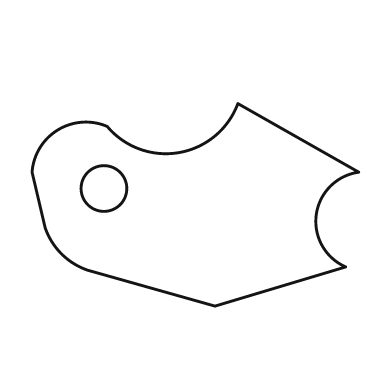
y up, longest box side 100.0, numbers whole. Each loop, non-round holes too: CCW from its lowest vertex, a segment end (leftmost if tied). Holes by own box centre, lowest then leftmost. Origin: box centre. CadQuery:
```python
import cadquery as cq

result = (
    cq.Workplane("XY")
    .moveTo(6.0, -31.0)
    .lineTo(46.0, -19.0)
    .threePointArc((37.0, -3.0), (50.0, 10.0))
    .lineTo(13.0, 31.0)
    .threePointArc((-5.0, 16.0), (-27.0, 24.0))
    .threePointArc((-42.0, 23.0), (-50.0, 10.0))
    .lineTo(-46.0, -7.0)
    .threePointArc((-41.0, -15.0), (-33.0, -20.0))
    .close()
    .moveTo(-28.0, 5.0)
    .circle(7.0)
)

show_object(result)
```